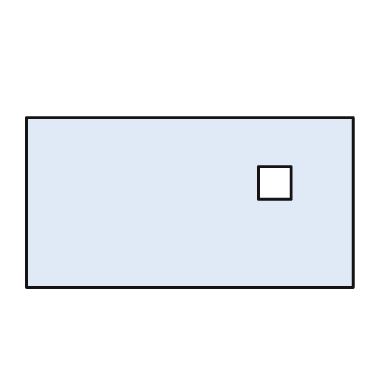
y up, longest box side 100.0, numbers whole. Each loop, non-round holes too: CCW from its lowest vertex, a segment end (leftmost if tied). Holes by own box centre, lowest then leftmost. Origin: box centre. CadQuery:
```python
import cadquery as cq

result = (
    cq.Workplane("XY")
    .moveTo(-50.0, -26.0)
    .lineTo(50.0, -26.0)
    .lineTo(50.0, 26.0)
    .lineTo(-50.0, 26.0)
    .close()
    .moveTo(21.0, 1.0)
    .lineTo(31.0, 1.0)
    .lineTo(31.0, 11.0)
    .lineTo(21.0, 11.0)
    .close()
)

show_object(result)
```